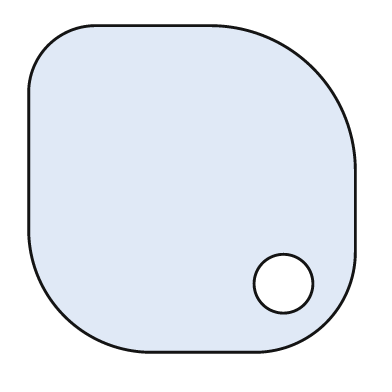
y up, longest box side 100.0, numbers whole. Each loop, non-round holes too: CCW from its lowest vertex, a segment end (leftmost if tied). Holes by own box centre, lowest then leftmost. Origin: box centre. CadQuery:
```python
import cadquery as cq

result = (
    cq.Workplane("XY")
    .moveTo(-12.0, -50.0)
    .lineTo(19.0, -50.0)
    .threePointArc((41.0, -41.0), (50.0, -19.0))
    .lineTo(50.0, 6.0)
    .threePointArc((37.0, 37.0), (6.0, 50.0))
    .lineTo(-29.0, 50.0)
    .threePointArc((-44.0, 44.0), (-50.0, 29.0))
    .lineTo(-50.0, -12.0)
    .threePointArc((-39.0, -39.0), (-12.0, -50.0))
    .close()
    .moveTo(28.0, -29.0)
    .circle(9.0)
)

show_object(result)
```